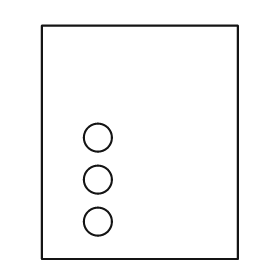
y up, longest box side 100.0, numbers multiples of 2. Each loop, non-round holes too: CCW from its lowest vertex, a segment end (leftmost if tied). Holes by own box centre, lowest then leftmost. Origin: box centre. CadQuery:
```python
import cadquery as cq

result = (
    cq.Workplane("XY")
    .moveTo(-42.0, -50.0)
    .lineTo(42.0, -50.0)
    .lineTo(42.0, 50.0)
    .lineTo(-42.0, 50.0)
    .close()
    .moveTo(-18.0, -34.0)
    .circle(6.0)
    .moveTo(-18.0, -16.0)
    .circle(6.0)
    .moveTo(-18.0, 2.0)
    .circle(6.0)
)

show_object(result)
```